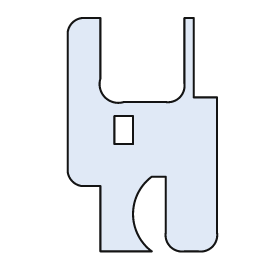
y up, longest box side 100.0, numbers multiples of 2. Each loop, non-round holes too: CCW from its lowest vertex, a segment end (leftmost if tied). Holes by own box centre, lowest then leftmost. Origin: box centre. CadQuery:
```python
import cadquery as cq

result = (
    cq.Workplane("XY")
    .moveTo(-18.0, -50.0)
    .lineTo(4.0, -50.0)
    .threePointArc((-4.0, -34.0), (4.0, -18.0))
    .lineTo(10.0, -18.0)
    .lineTo(10.0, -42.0)
    .threePointArc((12.0, -48.0), (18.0, -50.0))
    .lineTo(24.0, -50.0)
    .threePointArc((30.0, -48.0), (32.0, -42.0))
    .lineTo(32.0, 16.0)
    .lineTo(22.0, 16.0)
    .lineTo(22.0, 50.0)
    .lineTo(18.0, 50.0)
    .lineTo(18.0, 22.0)
    .threePointArc((16.0, 16.0), (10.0, 14.0))
    .lineTo(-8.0, 14.0)
    .threePointArc((-16.0, 16.0), (-18.0, 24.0))
    .lineTo(-18.0, 50.0)
    .lineTo(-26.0, 50.0)
    .threePointArc((-30.0, 48.0), (-32.0, 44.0))
    .lineTo(-32.0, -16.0)
    .threePointArc((-30.0, -20.0), (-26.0, -22.0))
    .lineTo(-18.0, -22.0)
    .close()
    .moveTo(-12.0, -4.0)
    .lineTo(-4.0, -4.0)
    .lineTo(-4.0, 8.0)
    .lineTo(-12.0, 8.0)
    .close()
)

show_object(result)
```